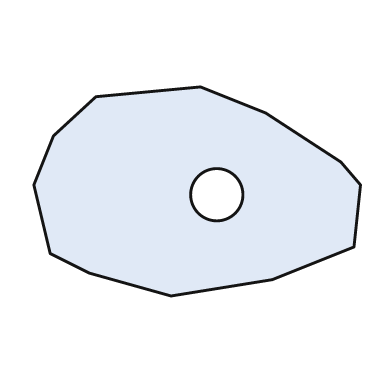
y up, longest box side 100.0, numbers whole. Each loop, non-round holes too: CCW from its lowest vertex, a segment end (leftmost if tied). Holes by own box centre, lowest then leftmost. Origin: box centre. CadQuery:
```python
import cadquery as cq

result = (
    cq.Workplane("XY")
    .moveTo(-8.0, -32.0)
    .lineTo(23.0, -27.0)
    .lineTo(48.0, -17.0)
    .lineTo(50.0, 2.0)
    .lineTo(44.0, 9.0)
    .lineTo(21.0, 24.0)
    .lineTo(1.0, 32.0)
    .lineTo(-31.0, 29.0)
    .lineTo(-44.0, 17.0)
    .lineTo(-50.0, 2.0)
    .lineTo(-45.0, -19.0)
    .lineTo(-33.0, -25.0)
    .close()
    .moveTo(6.0, -1.0)
    .circle(8.0)
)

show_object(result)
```